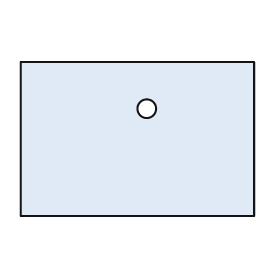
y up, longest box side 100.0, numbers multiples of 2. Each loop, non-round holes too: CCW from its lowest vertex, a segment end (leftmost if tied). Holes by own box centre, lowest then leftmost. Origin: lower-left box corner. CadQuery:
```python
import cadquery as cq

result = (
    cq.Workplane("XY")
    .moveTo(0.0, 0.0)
    .lineTo(100.0, 0.0)
    .lineTo(100.0, 66.0)
    .lineTo(0.0, 66.0)
    .close()
    .moveTo(54.0, 46.0)
    .circle(4.0)
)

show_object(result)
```